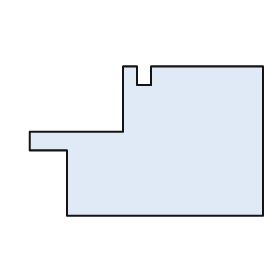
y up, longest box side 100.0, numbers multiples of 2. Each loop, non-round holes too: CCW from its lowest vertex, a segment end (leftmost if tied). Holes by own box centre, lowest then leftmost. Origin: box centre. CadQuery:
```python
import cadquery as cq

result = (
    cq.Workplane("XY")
    .moveTo(-34.0, -32.0)
    .lineTo(50.0, -32.0)
    .lineTo(50.0, 32.0)
    .lineTo(2.0, 32.0)
    .lineTo(2.0, 24.0)
    .lineTo(-4.0, 24.0)
    .lineTo(-4.0, 32.0)
    .lineTo(-10.0, 32.0)
    .lineTo(-10.0, 4.0)
    .lineTo(-50.0, 4.0)
    .lineTo(-50.0, -4.0)
    .lineTo(-34.0, -4.0)
    .close()
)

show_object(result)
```